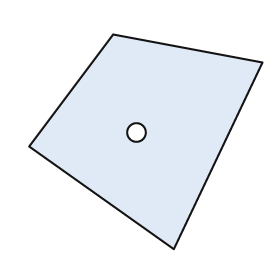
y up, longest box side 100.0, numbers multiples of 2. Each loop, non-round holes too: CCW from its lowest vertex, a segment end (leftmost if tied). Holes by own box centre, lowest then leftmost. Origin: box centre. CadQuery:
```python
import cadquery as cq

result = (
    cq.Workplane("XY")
    .moveTo(12.0, -46.0)
    .lineTo(50.0, 34.0)
    .lineTo(-14.0, 46.0)
    .lineTo(-50.0, -2.0)
    .close()
    .moveTo(-4.0, 4.0)
    .circle(4.0)
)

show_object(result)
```